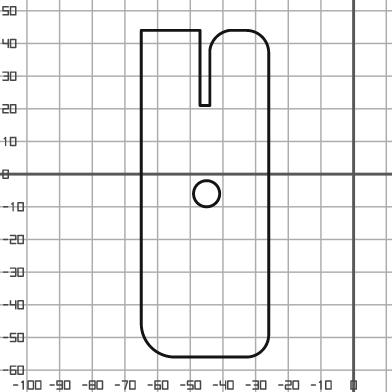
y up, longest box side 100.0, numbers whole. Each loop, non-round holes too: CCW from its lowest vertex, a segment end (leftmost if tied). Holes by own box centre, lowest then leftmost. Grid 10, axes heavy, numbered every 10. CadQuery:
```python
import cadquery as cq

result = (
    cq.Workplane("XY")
    .moveTo(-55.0, -56.0)
    .lineTo(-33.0, -56.0)
    .threePointArc((-28.0, -54.0), (-26.0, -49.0))
    .lineTo(-26.0, 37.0)
    .threePointArc((-28.0, 42.0), (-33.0, 44.0))
    .lineTo(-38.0, 44.0)
    .threePointArc((-42.0, 42.0), (-44.0, 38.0))
    .lineTo(-44.0, 21.0)
    .lineTo(-47.0, 21.0)
    .lineTo(-47.0, 44.0)
    .lineTo(-65.0, 44.0)
    .lineTo(-65.0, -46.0)
    .threePointArc((-62.0, -53.0), (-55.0, -56.0))
    .close()
    .moveTo(-45.0, -6.0)
    .circle(4.0)
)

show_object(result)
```